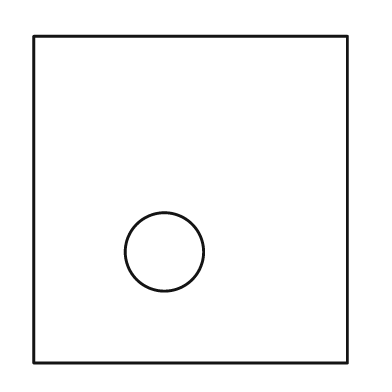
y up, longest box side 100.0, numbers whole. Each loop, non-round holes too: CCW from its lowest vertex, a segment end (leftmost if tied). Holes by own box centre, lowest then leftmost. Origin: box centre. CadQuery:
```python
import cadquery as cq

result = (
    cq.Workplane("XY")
    .moveTo(-48.0, -50.0)
    .lineTo(48.0, -50.0)
    .lineTo(48.0, 50.0)
    .lineTo(-48.0, 50.0)
    .close()
    .moveTo(-8.0, -16.0)
    .circle(12.0)
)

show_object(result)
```